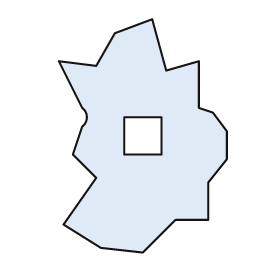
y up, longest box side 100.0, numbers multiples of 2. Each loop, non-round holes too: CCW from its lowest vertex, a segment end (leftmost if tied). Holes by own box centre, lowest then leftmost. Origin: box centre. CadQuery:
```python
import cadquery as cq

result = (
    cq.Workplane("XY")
    .moveTo(0.0, -50.0)
    .lineTo(14.0, -36.0)
    .lineTo(28.0, -36.0)
    .lineTo(28.0, -20.0)
    .lineTo(36.0, -10.0)
    .lineTo(36.0, 2.0)
    .lineTo(30.0, 10.0)
    .lineTo(24.0, 12.0)
    .lineTo(24.0, 32.0)
    .lineTo(10.0, 28.0)
    .lineTo(4.0, 50.0)
    .lineTo(-12.0, 44.0)
    .lineTo(-20.0, 30.0)
    .lineTo(-36.0, 32.0)
    .lineTo(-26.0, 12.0)
    .threePointArc((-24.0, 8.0), (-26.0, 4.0))
    .lineTo(-30.0, -8.0)
    .lineTo(-20.0, -18.0)
    .lineTo(-34.0, -38.0)
    .lineTo(-18.0, -48.0)
    .close()
    .moveTo(-8.0, -8.0)
    .lineTo(8.0, -8.0)
    .lineTo(8.0, 8.0)
    .lineTo(-8.0, 8.0)
    .close()
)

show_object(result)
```